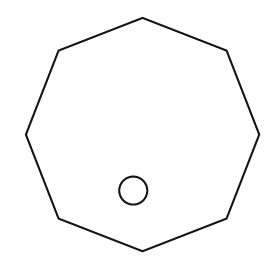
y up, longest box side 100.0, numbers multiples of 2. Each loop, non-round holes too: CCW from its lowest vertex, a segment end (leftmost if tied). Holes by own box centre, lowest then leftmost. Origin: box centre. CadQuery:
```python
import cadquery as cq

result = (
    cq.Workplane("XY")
    .moveTo(0.0, -50.0)
    .lineTo(36.0, -36.0)
    .lineTo(50.0, 0.0)
    .lineTo(36.0, 36.0)
    .lineTo(0.0, 50.0)
    .lineTo(-36.0, 36.0)
    .lineTo(-50.0, 0.0)
    .lineTo(-36.0, -36.0)
    .close()
    .moveTo(-4.0, -24.0)
    .circle(6.0)
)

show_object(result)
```